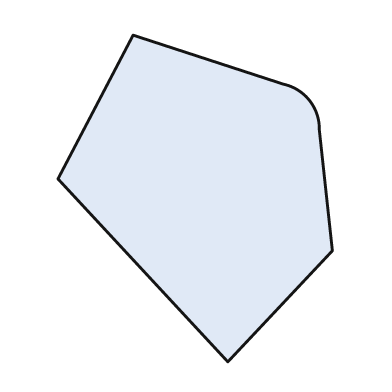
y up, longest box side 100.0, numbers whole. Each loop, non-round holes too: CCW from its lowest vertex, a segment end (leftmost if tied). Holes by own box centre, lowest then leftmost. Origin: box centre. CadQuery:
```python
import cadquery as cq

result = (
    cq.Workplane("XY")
    .moveTo(10.0, -50.0)
    .lineTo(42.0, -16.0)
    .lineTo(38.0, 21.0)
    .threePointArc((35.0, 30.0), (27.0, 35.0))
    .lineTo(-19.0, 50.0)
    .lineTo(-42.0, 6.0)
    .close()
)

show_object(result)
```